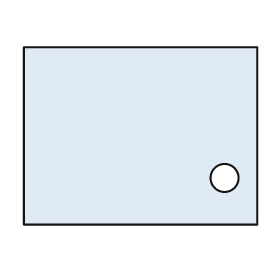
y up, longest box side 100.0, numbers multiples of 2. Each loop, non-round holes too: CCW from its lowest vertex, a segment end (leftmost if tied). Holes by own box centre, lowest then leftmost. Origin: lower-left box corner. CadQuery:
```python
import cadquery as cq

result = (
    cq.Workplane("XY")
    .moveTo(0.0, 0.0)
    .lineTo(100.0, 0.0)
    .lineTo(100.0, 76.0)
    .lineTo(0.0, 76.0)
    .close()
    .moveTo(86.0, 20.0)
    .circle(6.0)
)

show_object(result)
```